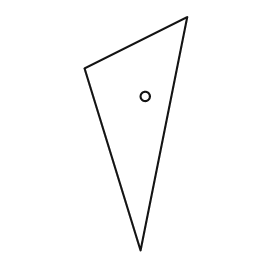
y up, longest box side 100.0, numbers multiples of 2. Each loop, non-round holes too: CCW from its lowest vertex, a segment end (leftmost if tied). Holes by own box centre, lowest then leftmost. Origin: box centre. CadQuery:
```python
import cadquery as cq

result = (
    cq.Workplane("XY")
    .moveTo(2.0, -50.0)
    .lineTo(22.0, 50.0)
    .lineTo(-22.0, 28.0)
    .close()
    .moveTo(4.0, 16.0)
    .circle(2.0)
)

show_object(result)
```